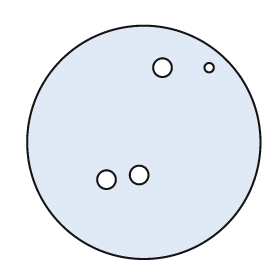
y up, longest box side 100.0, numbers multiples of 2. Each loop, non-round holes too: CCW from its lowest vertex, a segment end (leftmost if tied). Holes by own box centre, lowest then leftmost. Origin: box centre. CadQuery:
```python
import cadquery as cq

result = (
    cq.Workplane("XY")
    .moveTo(0.0, 0.0)
    .circle(50.0)
    .moveTo(-16.0, -16.0)
    .circle(4.0)
    .moveTo(-2.0, -14.0)
    .circle(4.0)
    .moveTo(8.0, 32.0)
    .circle(4.0)
    .moveTo(28.0, 32.0)
    .circle(2.0)
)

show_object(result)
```